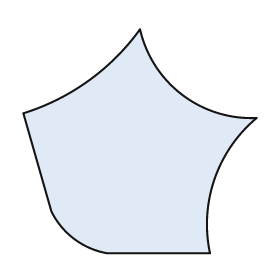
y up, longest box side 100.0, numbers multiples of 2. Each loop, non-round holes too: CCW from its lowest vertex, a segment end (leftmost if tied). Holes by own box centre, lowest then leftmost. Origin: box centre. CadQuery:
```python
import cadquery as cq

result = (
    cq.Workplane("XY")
    .moveTo(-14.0, -48.0)
    .lineTo(30.0, -48.0)
    .threePointArc((32.0, -16.0), (50.0, 10.0))
    .threePointArc((18.0, 20.0), (0.0, 48.0))
    .threePointArc((-22.0, 26.0), (-50.0, 12.0))
    .lineTo(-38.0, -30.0)
    .threePointArc((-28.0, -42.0), (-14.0, -48.0))
    .close()
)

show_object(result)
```